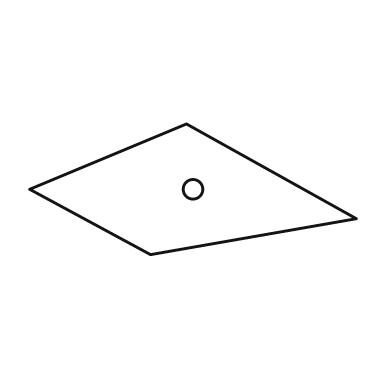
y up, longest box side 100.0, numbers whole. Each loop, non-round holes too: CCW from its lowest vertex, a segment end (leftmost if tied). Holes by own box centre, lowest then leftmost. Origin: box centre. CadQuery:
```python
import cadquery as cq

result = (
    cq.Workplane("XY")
    .moveTo(-13.0, -20.0)
    .lineTo(50.0, -9.0)
    .lineTo(-2.0, 20.0)
    .lineTo(-50.0, 0.0)
    .close()
    .moveTo(0.0, 0.0)
    .circle(3.0)
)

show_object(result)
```